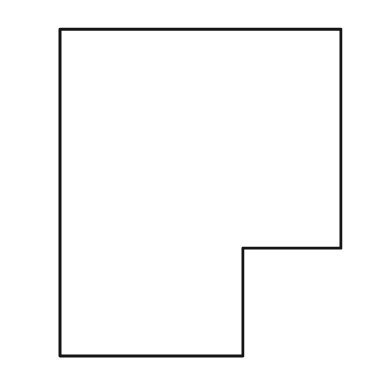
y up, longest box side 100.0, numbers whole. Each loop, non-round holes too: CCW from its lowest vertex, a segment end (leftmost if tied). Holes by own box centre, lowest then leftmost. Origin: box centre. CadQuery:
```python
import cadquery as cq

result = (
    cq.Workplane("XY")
    .moveTo(-43.0, -50.0)
    .lineTo(13.0, -50.0)
    .lineTo(13.0, -17.0)
    .lineTo(43.0, -17.0)
    .lineTo(43.0, 50.0)
    .lineTo(-43.0, 50.0)
    .close()
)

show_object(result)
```